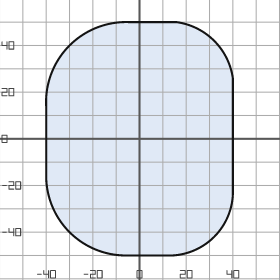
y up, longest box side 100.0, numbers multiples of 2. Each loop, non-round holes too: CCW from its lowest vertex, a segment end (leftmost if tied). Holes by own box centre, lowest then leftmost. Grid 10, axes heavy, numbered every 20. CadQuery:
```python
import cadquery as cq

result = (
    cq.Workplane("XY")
    .moveTo(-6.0, -50.0)
    .lineTo(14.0, -50.0)
    .threePointArc((32.0, -42.0), (40.0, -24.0))
    .lineTo(40.0, 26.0)
    .threePointArc((32.0, 42.0), (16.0, 50.0))
    .lineTo(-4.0, 50.0)
    .threePointArc((-30.0, 40.0), (-40.0, 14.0))
    .lineTo(-40.0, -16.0)
    .threePointArc((-30.0, -40.0), (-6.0, -50.0))
    .close()
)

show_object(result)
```